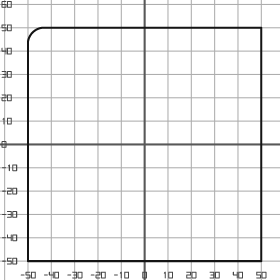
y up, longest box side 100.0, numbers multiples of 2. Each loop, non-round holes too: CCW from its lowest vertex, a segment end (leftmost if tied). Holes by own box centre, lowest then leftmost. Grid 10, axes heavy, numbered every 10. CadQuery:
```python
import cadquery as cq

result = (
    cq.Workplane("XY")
    .moveTo(-50.0, -50.0)
    .lineTo(50.0, -50.0)
    .lineTo(50.0, 50.0)
    .lineTo(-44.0, 50.0)
    .threePointArc((-48.0, 48.0), (-50.0, 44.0))
    .close()
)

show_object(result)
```